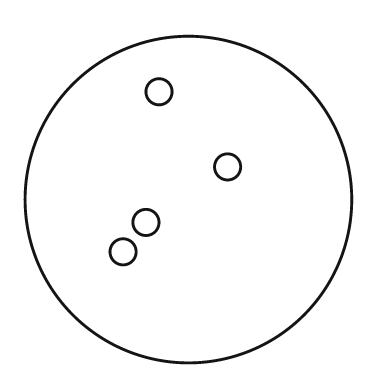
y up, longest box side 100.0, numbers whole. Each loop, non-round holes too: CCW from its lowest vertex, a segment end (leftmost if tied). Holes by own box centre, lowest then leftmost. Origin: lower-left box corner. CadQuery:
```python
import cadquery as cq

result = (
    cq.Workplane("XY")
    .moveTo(50.0, 50.0)
    .circle(50.0)
    .moveTo(30.0, 34.0)
    .circle(4.0)
    .moveTo(37.0, 43.0)
    .circle(4.0)
    .moveTo(62.0, 60.0)
    .circle(4.0)
    .moveTo(41.0, 83.0)
    .circle(4.0)
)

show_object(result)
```